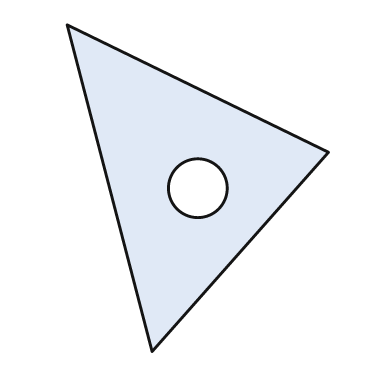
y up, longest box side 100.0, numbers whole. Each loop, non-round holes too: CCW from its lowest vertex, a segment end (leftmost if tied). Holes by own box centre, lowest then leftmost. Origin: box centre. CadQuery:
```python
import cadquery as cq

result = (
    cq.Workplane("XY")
    .moveTo(-14.0, -50.0)
    .lineTo(40.0, 11.0)
    .lineTo(-40.0, 50.0)
    .close()
    .moveTo(0.0, 0.0)
    .circle(9.0)
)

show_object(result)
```